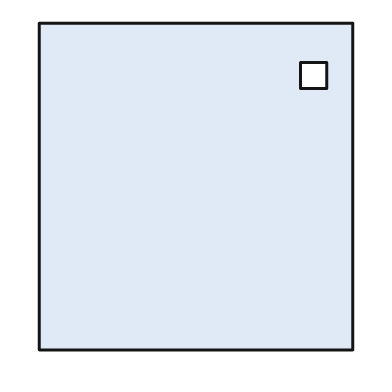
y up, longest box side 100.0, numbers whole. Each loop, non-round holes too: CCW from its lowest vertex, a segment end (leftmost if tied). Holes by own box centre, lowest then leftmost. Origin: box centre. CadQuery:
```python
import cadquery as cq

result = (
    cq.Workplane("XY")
    .moveTo(-48.0, -50.0)
    .lineTo(48.0, -50.0)
    .lineTo(48.0, 50.0)
    .lineTo(-48.0, 50.0)
    .close()
    .moveTo(32.0, 30.0)
    .lineTo(40.0, 30.0)
    .lineTo(40.0, 38.0)
    .lineTo(32.0, 38.0)
    .close()
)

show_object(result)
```